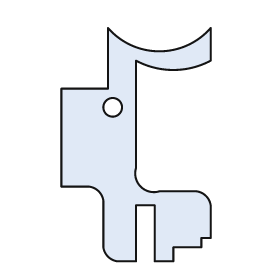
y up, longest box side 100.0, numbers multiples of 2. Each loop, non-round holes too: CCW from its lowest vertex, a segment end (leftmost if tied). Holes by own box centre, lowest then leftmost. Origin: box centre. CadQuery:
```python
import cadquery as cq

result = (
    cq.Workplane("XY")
    .moveTo(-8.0, -50.0)
    .lineTo(0.0, -50.0)
    .lineTo(0.0, -26.0)
    .lineTo(8.0, -26.0)
    .lineTo(8.0, -50.0)
    .lineTo(16.0, -50.0)
    .lineTo(16.0, -44.0)
    .lineTo(28.0, -44.0)
    .lineTo(28.0, -40.0)
    .lineTo(32.0, -40.0)
    .lineTo(32.0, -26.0)
    .threePointArc((30.0, -22.0), (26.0, -20.0))
    .lineTo(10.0, -20.0)
    .threePointArc((2.0, -18.0), (0.0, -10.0))
    .lineTo(0.0, 36.0)
    .threePointArc((16.0, 32.0), (32.0, 36.0))
    .lineTo(32.0, 50.0)
    .threePointArc((10.0, 40.0), (-12.0, 50.0))
    .lineTo(-12.0, 24.0)
    .lineTo(-32.0, 24.0)
    .lineTo(-32.0, -18.0)
    .lineTo(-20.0, -18.0)
    .threePointArc((-16.0, -20.0), (-14.0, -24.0))
    .lineTo(-14.0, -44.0)
    .threePointArc((-12.0, -48.0), (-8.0, -50.0))
    .close()
    .moveTo(-10.0, 16.0)
    .circle(4.0)
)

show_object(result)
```